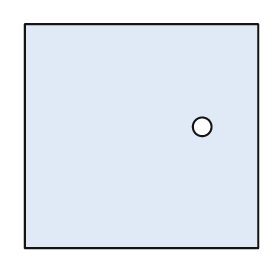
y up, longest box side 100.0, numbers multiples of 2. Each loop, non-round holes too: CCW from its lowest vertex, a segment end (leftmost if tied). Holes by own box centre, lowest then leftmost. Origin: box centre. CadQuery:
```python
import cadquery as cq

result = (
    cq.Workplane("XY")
    .moveTo(-50.0, -48.0)
    .lineTo(50.0, -48.0)
    .lineTo(50.0, 48.0)
    .lineTo(-50.0, 48.0)
    .close()
    .moveTo(26.0, 4.0)
    .circle(4.0)
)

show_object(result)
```